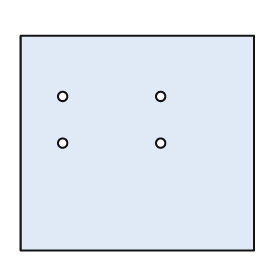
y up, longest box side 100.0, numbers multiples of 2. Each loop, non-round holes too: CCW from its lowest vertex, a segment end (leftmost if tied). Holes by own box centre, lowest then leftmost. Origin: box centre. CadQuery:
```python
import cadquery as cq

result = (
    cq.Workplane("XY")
    .moveTo(-50.0, -46.0)
    .lineTo(50.0, -46.0)
    .lineTo(50.0, 46.0)
    .lineTo(-50.0, 46.0)
    .close()
    .moveTo(-32.0, 0.0)
    .circle(2.0)
    .moveTo(10.0, 0.0)
    .circle(2.0)
    .moveTo(-32.0, 20.0)
    .circle(2.0)
    .moveTo(10.0, 20.0)
    .circle(2.0)
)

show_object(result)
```